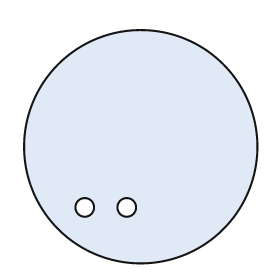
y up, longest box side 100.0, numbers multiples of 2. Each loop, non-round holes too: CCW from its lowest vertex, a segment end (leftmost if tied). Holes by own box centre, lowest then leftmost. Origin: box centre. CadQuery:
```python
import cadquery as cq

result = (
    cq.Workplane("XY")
    .moveTo(0.0, 0.0)
    .circle(50.0)
    .moveTo(-24.0, -26.0)
    .circle(4.0)
    .moveTo(-6.0, -26.0)
    .circle(4.0)
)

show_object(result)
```